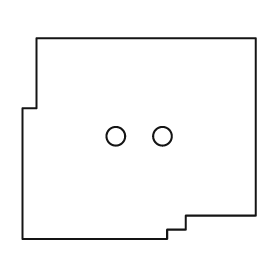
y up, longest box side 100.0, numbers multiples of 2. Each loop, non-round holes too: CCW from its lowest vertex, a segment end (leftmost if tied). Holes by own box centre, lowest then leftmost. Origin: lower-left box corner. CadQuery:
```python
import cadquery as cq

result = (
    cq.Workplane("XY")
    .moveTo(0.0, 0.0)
    .lineTo(62.0, 0.0)
    .lineTo(62.0, 4.0)
    .lineTo(70.0, 4.0)
    .lineTo(70.0, 10.0)
    .lineTo(100.0, 10.0)
    .lineTo(100.0, 86.0)
    .lineTo(6.0, 86.0)
    .lineTo(6.0, 56.0)
    .lineTo(0.0, 56.0)
    .close()
    .moveTo(40.0, 44.0)
    .circle(4.0)
    .moveTo(60.0, 44.0)
    .circle(4.0)
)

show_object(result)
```